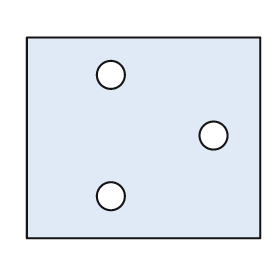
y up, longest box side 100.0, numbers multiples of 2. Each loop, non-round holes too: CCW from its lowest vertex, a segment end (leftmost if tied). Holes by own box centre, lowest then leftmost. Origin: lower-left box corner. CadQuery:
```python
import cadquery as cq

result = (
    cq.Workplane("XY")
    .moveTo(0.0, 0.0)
    .lineTo(100.0, 0.0)
    .lineTo(100.0, 86.0)
    .lineTo(0.0, 86.0)
    .close()
    .moveTo(36.0, 18.0)
    .circle(6.0)
    .moveTo(80.0, 44.0)
    .circle(6.0)
    .moveTo(36.0, 70.0)
    .circle(6.0)
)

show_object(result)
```